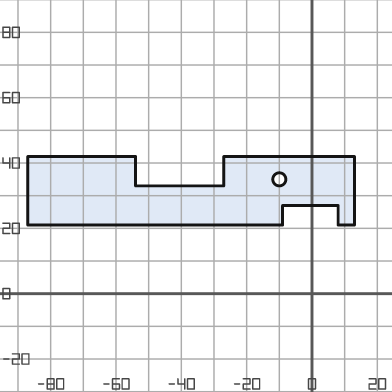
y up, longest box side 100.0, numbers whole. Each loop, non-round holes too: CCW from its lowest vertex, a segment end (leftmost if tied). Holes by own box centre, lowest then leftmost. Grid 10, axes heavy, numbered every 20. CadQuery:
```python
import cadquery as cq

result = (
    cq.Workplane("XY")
    .moveTo(-87.0, 21.0)
    .lineTo(-9.0, 21.0)
    .lineTo(-9.0, 27.0)
    .lineTo(8.0, 27.0)
    .lineTo(8.0, 21.0)
    .lineTo(13.0, 21.0)
    .lineTo(13.0, 42.0)
    .lineTo(-27.0, 42.0)
    .lineTo(-27.0, 33.0)
    .lineTo(-54.0, 33.0)
    .lineTo(-54.0, 42.0)
    .lineTo(-87.0, 42.0)
    .close()
    .moveTo(-10.0, 35.0)
    .circle(2.0)
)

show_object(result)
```